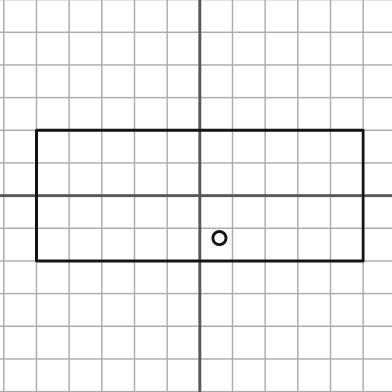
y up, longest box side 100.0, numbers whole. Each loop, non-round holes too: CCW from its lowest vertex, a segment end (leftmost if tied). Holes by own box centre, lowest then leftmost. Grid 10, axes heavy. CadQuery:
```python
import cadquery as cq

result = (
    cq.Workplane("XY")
    .moveTo(-50.0, -20.0)
    .lineTo(50.0, -20.0)
    .lineTo(50.0, 20.0)
    .lineTo(-50.0, 20.0)
    .close()
    .moveTo(6.0, -13.0)
    .circle(2.0)
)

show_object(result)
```